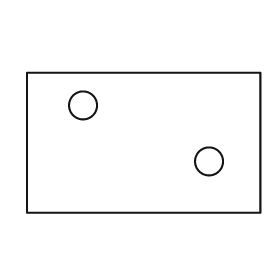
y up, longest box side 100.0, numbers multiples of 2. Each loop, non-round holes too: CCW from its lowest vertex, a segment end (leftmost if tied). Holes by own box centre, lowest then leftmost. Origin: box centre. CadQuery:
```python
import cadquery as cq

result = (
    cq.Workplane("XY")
    .moveTo(-50.0, -30.0)
    .lineTo(50.0, -30.0)
    .lineTo(50.0, 30.0)
    .lineTo(-50.0, 30.0)
    .close()
    .moveTo(28.0, -8.0)
    .circle(6.0)
    .moveTo(-26.0, 16.0)
    .circle(6.0)
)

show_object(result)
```